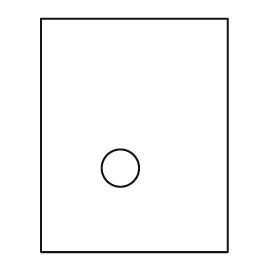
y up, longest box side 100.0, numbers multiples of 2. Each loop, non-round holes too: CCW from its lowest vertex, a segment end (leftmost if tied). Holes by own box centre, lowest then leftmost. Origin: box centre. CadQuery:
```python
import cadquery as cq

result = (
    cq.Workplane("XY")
    .moveTo(-40.0, -50.0)
    .lineTo(40.0, -50.0)
    .lineTo(40.0, 50.0)
    .lineTo(-40.0, 50.0)
    .close()
    .moveTo(-6.0, -14.0)
    .circle(8.0)
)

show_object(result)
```